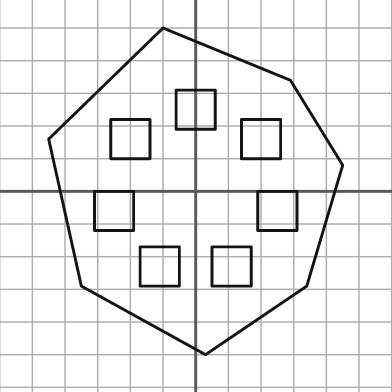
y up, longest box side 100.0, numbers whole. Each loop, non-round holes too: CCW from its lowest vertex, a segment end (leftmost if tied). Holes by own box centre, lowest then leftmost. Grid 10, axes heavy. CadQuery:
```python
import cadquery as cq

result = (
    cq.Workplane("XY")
    .moveTo(3.0, -50.0)
    .lineTo(34.0, -29.0)
    .lineTo(45.0, 8.0)
    .lineTo(29.0, 34.0)
    .lineTo(-10.0, 50.0)
    .lineTo(-45.0, 16.0)
    .lineTo(-35.0, -29.0)
    .close()
    .moveTo(-17.0, -29.0)
    .lineTo(-5.0, -29.0)
    .lineTo(-5.0, -17.0)
    .lineTo(-17.0, -17.0)
    .close()
    .moveTo(5.0, -29.0)
    .lineTo(17.0, -29.0)
    .lineTo(17.0, -17.0)
    .lineTo(5.0, -17.0)
    .close()
    .moveTo(-31.0, -12.0)
    .lineTo(-19.0, -12.0)
    .lineTo(-19.0, 0.0)
    .lineTo(-31.0, 0.0)
    .close()
    .moveTo(19.0, -12.0)
    .lineTo(31.0, -12.0)
    .lineTo(31.0, 0.0)
    .lineTo(19.0, 0.0)
    .close()
    .moveTo(-26.0, 10.0)
    .lineTo(-14.0, 10.0)
    .lineTo(-14.0, 22.0)
    .lineTo(-26.0, 22.0)
    .close()
    .moveTo(14.0, 10.0)
    .lineTo(26.0, 10.0)
    .lineTo(26.0, 22.0)
    .lineTo(14.0, 22.0)
    .close()
    .moveTo(-6.0, 19.0)
    .lineTo(6.0, 19.0)
    .lineTo(6.0, 31.0)
    .lineTo(-6.0, 31.0)
    .close()
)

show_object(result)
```